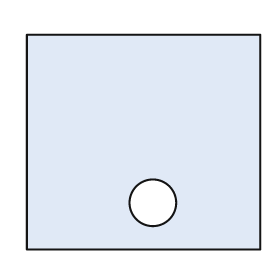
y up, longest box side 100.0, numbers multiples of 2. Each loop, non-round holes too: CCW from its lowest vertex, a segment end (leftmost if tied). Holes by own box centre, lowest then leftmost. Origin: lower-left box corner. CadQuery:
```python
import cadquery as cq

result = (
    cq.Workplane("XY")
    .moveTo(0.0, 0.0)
    .lineTo(100.0, 0.0)
    .lineTo(100.0, 92.0)
    .lineTo(0.0, 92.0)
    .close()
    .moveTo(54.0, 20.0)
    .circle(10.0)
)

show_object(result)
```